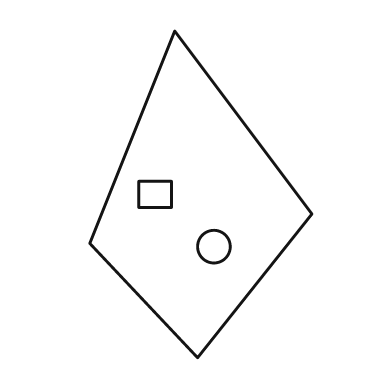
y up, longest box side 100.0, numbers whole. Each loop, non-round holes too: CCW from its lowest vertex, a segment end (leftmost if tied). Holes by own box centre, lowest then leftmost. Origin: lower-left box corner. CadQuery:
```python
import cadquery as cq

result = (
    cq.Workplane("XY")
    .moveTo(33.0, 0.0)
    .lineTo(68.0, 44.0)
    .lineTo(26.0, 100.0)
    .lineTo(0.0, 35.0)
    .close()
    .moveTo(38.0, 34.0)
    .circle(5.0)
    .moveTo(15.0, 46.0)
    .lineTo(25.0, 46.0)
    .lineTo(25.0, 54.0)
    .lineTo(15.0, 54.0)
    .close()
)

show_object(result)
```